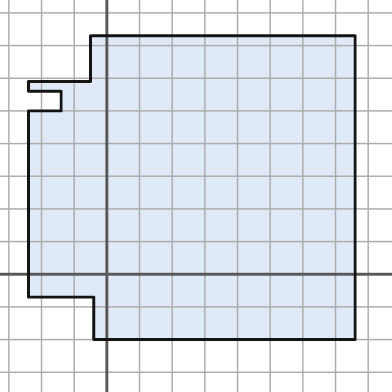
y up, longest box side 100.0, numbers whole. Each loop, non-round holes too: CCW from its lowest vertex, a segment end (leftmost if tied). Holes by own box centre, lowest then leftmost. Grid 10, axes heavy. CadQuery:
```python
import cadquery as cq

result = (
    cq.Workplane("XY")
    .moveTo(-4.0, -20.0)
    .lineTo(76.0, -20.0)
    .lineTo(76.0, 73.0)
    .lineTo(-5.0, 73.0)
    .lineTo(-5.0, 59.0)
    .lineTo(-24.0, 59.0)
    .lineTo(-24.0, 56.0)
    .lineTo(-14.0, 56.0)
    .lineTo(-14.0, 50.0)
    .lineTo(-24.0, 50.0)
    .lineTo(-24.0, -7.0)
    .lineTo(-4.0, -7.0)
    .close()
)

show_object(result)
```